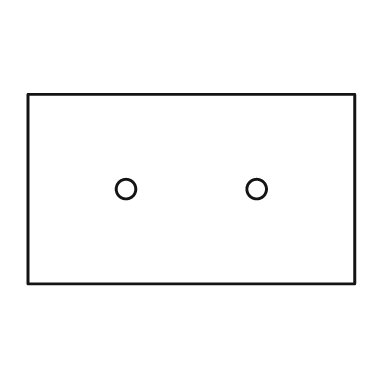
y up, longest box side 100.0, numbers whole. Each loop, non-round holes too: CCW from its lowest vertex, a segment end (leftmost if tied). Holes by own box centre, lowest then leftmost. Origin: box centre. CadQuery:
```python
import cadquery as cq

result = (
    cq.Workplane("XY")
    .moveTo(-50.0, -29.0)
    .lineTo(50.0, -29.0)
    .lineTo(50.0, 29.0)
    .lineTo(-50.0, 29.0)
    .close()
    .moveTo(-20.0, 0.0)
    .circle(3.0)
    .moveTo(20.0, 0.0)
    .circle(3.0)
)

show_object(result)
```